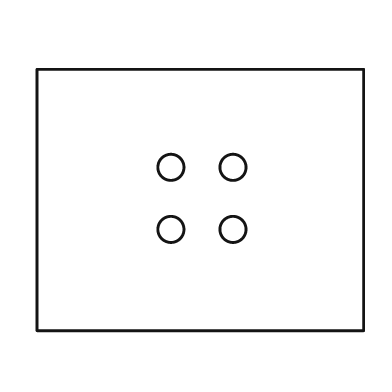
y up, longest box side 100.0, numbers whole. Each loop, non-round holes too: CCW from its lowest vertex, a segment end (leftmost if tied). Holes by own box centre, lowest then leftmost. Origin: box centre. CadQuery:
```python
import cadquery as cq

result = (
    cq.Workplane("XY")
    .moveTo(-50.0, -40.0)
    .lineTo(50.0, -40.0)
    .lineTo(50.0, 40.0)
    .lineTo(-50.0, 40.0)
    .close()
    .moveTo(-9.0, -9.0)
    .circle(4.0)
    .moveTo(10.0, -9.0)
    .circle(4.0)
    .moveTo(-9.0, 10.0)
    .circle(4.0)
    .moveTo(10.0, 10.0)
    .circle(4.0)
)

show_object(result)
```